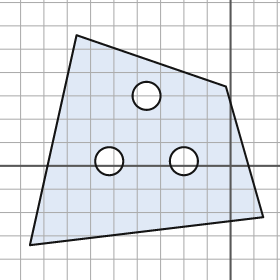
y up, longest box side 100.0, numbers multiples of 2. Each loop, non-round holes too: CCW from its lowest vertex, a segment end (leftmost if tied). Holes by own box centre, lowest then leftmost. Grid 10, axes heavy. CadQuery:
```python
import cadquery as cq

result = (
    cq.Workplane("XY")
    .moveTo(-86.0, -34.0)
    .lineTo(14.0, -22.0)
    .lineTo(-2.0, 34.0)
    .lineTo(-66.0, 56.0)
    .close()
    .moveTo(-52.0, 2.0)
    .circle(6.0)
    .moveTo(-20.0, 2.0)
    .circle(6.0)
    .moveTo(-36.0, 30.0)
    .circle(6.0)
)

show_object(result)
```